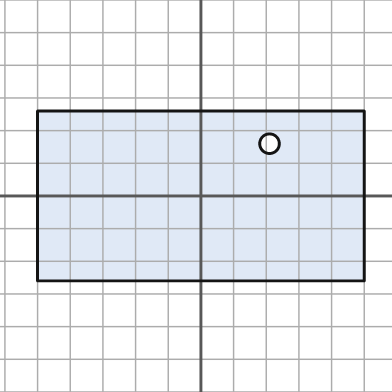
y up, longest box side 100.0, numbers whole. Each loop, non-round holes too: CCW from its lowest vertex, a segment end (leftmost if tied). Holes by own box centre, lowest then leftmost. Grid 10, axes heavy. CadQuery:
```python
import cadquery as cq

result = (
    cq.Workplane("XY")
    .moveTo(-50.0, -26.0)
    .lineTo(50.0, -26.0)
    .lineTo(50.0, 26.0)
    .lineTo(-50.0, 26.0)
    .close()
    .moveTo(21.0, 16.0)
    .circle(3.0)
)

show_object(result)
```